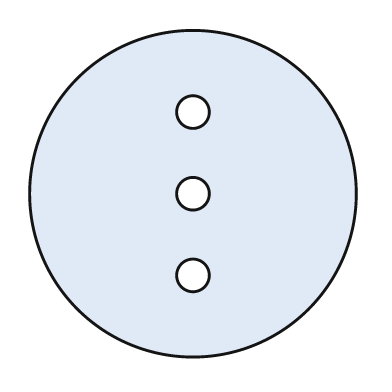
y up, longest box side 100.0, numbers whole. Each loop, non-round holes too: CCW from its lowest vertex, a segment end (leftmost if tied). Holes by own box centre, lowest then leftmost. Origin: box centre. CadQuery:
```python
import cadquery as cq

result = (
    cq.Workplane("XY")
    .moveTo(0.0, 0.0)
    .circle(50.0)
    .moveTo(0.0, -25.0)
    .circle(5.0)
    .moveTo(0.0, 0.0)
    .circle(5.0)
    .moveTo(0.0, 25.0)
    .circle(5.0)
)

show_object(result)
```